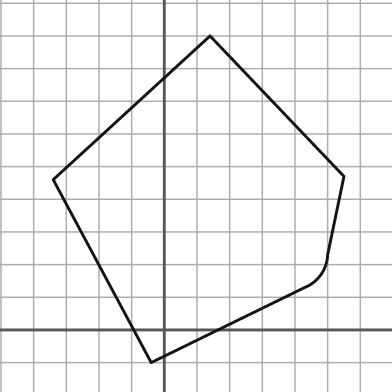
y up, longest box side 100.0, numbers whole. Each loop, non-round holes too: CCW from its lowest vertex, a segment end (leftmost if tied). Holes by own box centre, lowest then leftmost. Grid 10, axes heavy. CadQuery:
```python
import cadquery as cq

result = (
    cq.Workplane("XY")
    .moveTo(-4.0, -10.0)
    .lineTo(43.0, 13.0)
    .threePointArc((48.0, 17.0), (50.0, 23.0))
    .lineTo(55.0, 47.0)
    .lineTo(14.0, 90.0)
    .lineTo(-34.0, 46.0)
    .close()
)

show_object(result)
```